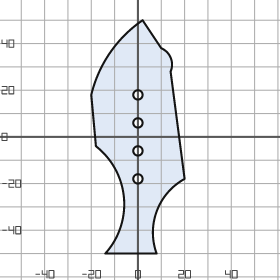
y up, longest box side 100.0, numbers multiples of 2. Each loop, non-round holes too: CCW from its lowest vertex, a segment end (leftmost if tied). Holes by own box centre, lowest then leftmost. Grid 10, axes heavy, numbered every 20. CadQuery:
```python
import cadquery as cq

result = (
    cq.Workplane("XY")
    .moveTo(-14.0, -50.0)
    .lineTo(8.0, -50.0)
    .threePointArc((8.0, -32.0), (20.0, -18.0))
    .lineTo(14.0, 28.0)
    .threePointArc((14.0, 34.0), (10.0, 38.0))
    .lineTo(2.0, 50.0)
    .threePointArc((-12.0, 36.0), (-20.0, 18.0))
    .lineTo(-18.0, -4.0)
    .threePointArc((-6.0, -26.0), (-14.0, -50.0))
    .close()
    .moveTo(0.0, -18.0)
    .circle(2.0)
    .moveTo(0.0, -6.0)
    .circle(2.0)
    .moveTo(0.0, 6.0)
    .circle(2.0)
    .moveTo(0.0, 18.0)
    .circle(2.0)
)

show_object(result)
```